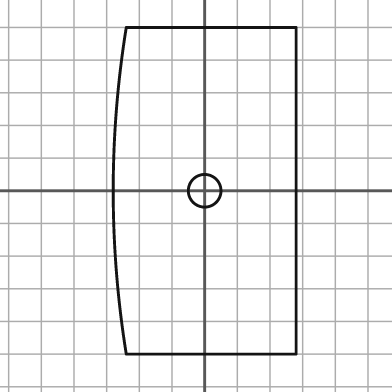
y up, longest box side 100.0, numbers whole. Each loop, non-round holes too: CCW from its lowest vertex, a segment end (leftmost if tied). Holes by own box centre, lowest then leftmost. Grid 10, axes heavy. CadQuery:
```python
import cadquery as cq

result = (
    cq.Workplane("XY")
    .moveTo(-24.0, -50.0)
    .lineTo(28.0, -50.0)
    .lineTo(28.0, 50.0)
    .lineTo(-24.0, 50.0)
    .threePointArc((-28.0, 0.0), (-24.0, -50.0))
    .close()
    .moveTo(0.0, 0.0)
    .circle(5.0)
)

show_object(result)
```